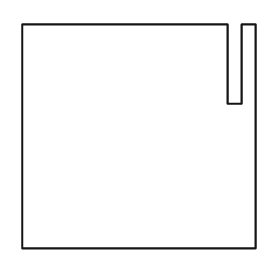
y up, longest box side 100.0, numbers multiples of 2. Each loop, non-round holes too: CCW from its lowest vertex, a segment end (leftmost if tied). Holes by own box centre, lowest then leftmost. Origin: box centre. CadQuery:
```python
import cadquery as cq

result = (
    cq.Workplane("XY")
    .moveTo(-50.0, -48.0)
    .lineTo(50.0, -48.0)
    .lineTo(50.0, 48.0)
    .lineTo(44.0, 48.0)
    .lineTo(44.0, 14.0)
    .lineTo(38.0, 14.0)
    .lineTo(38.0, 48.0)
    .lineTo(-50.0, 48.0)
    .close()
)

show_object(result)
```